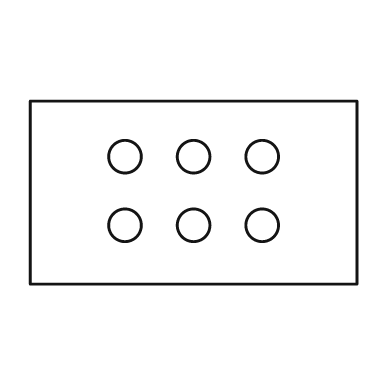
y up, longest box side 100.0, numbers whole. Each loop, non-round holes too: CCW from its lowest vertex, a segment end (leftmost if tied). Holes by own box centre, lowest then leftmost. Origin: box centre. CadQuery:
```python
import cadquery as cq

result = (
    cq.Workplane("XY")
    .moveTo(-50.0, -28.0)
    .lineTo(50.0, -28.0)
    .lineTo(50.0, 28.0)
    .lineTo(-50.0, 28.0)
    .close()
    .moveTo(-21.0, -10.0)
    .circle(5.0)
    .moveTo(0.0, -10.0)
    .circle(5.0)
    .moveTo(21.0, -10.0)
    .circle(5.0)
    .moveTo(-21.0, 11.0)
    .circle(5.0)
    .moveTo(0.0, 11.0)
    .circle(5.0)
    .moveTo(21.0, 11.0)
    .circle(5.0)
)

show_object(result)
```